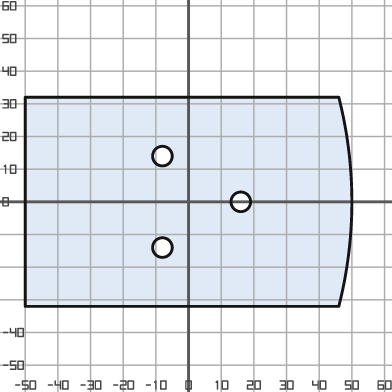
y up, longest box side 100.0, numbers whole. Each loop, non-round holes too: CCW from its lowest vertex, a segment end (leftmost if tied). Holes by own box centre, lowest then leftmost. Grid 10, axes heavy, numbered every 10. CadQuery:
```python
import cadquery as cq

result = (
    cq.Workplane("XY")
    .moveTo(-50.0, -32.0)
    .lineTo(46.0, -32.0)
    .threePointArc((50.0, 0.0), (46.0, 32.0))
    .lineTo(-50.0, 32.0)
    .close()
    .moveTo(-8.0, -14.0)
    .circle(3.0)
    .moveTo(16.0, 0.0)
    .circle(3.0)
    .moveTo(-8.0, 14.0)
    .circle(3.0)
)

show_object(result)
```